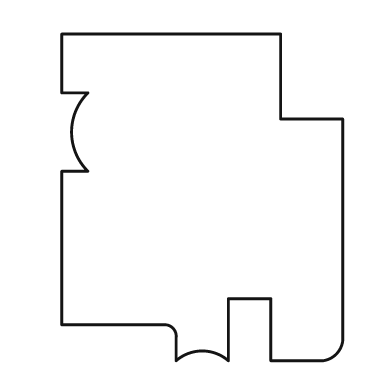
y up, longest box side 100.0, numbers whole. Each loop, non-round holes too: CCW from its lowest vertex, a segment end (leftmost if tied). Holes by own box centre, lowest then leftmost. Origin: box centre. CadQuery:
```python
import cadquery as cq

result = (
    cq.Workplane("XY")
    .moveTo(-8.0, -50.0)
    .threePointArc((0.0, -47.0), (8.0, -50.0))
    .lineTo(8.0, -31.0)
    .lineTo(21.0, -31.0)
    .lineTo(21.0, -50.0)
    .lineTo(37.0, -50.0)
    .threePointArc((41.0, -48.0), (43.0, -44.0))
    .lineTo(43.0, 24.0)
    .lineTo(24.0, 24.0)
    .lineTo(24.0, 50.0)
    .lineTo(-43.0, 50.0)
    .lineTo(-43.0, 32.0)
    .lineTo(-35.0, 32.0)
    .threePointArc((-40.0, 20.0), (-35.0, 8.0))
    .lineTo(-43.0, 8.0)
    .lineTo(-43.0, -39.0)
    .lineTo(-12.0, -39.0)
    .threePointArc((-9.0, -40.0), (-8.0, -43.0))
    .close()
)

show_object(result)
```